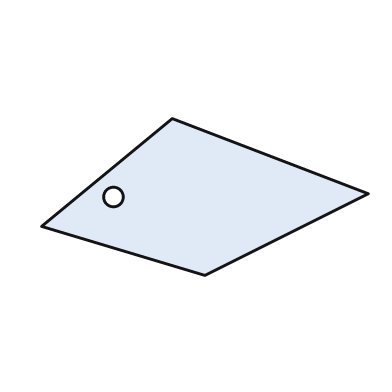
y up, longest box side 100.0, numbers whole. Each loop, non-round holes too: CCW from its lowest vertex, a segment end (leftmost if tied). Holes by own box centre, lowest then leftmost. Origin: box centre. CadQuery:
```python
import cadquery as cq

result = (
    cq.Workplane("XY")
    .moveTo(0.0, -24.0)
    .lineTo(50.0, 1.0)
    .lineTo(-10.0, 24.0)
    .lineTo(-50.0, -9.0)
    .close()
    .moveTo(-28.0, 0.0)
    .circle(3.0)
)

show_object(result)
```